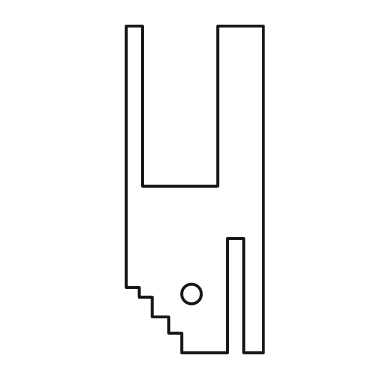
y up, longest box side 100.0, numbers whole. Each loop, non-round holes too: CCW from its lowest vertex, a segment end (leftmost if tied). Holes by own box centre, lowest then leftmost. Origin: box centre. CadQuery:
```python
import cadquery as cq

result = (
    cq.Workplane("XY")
    .moveTo(-4.0, -50.0)
    .lineTo(10.0, -50.0)
    .lineTo(10.0, -15.0)
    .lineTo(15.0, -15.0)
    .lineTo(15.0, -50.0)
    .lineTo(21.0, -50.0)
    .lineTo(21.0, 50.0)
    .lineTo(7.0, 50.0)
    .lineTo(7.0, 1.0)
    .lineTo(-16.0, 1.0)
    .lineTo(-16.0, 50.0)
    .lineTo(-21.0, 50.0)
    .lineTo(-21.0, -30.0)
    .lineTo(-17.0, -30.0)
    .lineTo(-17.0, -33.0)
    .lineTo(-13.0, -33.0)
    .lineTo(-13.0, -39.0)
    .lineTo(-8.0, -39.0)
    .lineTo(-8.0, -44.0)
    .lineTo(-4.0, -44.0)
    .close()
    .moveTo(-1.0, -32.0)
    .circle(3.0)
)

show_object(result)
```